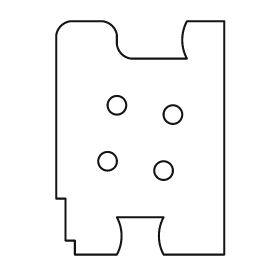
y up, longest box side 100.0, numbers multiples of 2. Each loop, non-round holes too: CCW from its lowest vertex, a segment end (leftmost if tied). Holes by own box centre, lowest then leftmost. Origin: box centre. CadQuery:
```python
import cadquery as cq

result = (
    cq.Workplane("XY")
    .moveTo(-28.0, -50.0)
    .lineTo(-10.0, -50.0)
    .threePointArc((-8.0, -42.0), (-10.0, -34.0))
    .lineTo(10.0, -34.0)
    .threePointArc((8.0, -42.0), (10.0, -50.0))
    .lineTo(36.0, -50.0)
    .lineTo(36.0, 50.0)
    .lineTo(20.0, 50.0)
    .threePointArc((18.0, 42.0), (20.0, 34.0))
    .lineTo(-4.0, 34.0)
    .threePointArc((-8.0, 36.0), (-10.0, 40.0))
    .lineTo(-10.0, 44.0)
    .threePointArc((-12.0, 48.0), (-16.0, 50.0))
    .lineTo(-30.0, 50.0)
    .threePointArc((-34.0, 48.0), (-36.0, 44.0))
    .lineTo(-36.0, -26.0)
    .lineTo(-32.0, -26.0)
    .lineTo(-32.0, -44.0)
    .lineTo(-28.0, -44.0)
    .close()
    .moveTo(10.0, -14.0)
    .circle(4.0)
    .moveTo(-14.0, -10.0)
    .circle(4.0)
    .moveTo(14.0, 10.0)
    .circle(4.0)
    .moveTo(-10.0, 14.0)
    .circle(4.0)
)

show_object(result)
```